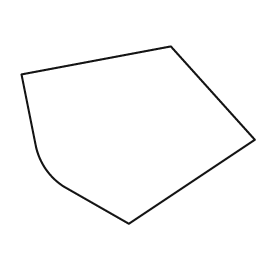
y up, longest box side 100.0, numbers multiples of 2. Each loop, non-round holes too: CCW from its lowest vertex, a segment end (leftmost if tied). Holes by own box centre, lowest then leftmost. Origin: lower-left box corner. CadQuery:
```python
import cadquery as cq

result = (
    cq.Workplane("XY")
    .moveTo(46.0, 0.0)
    .lineTo(100.0, 36.0)
    .lineTo(64.0, 76.0)
    .lineTo(0.0, 64.0)
    .lineTo(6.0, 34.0)
    .threePointArc((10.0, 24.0), (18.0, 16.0))
    .close()
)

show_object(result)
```